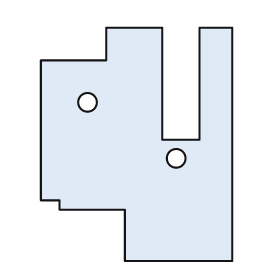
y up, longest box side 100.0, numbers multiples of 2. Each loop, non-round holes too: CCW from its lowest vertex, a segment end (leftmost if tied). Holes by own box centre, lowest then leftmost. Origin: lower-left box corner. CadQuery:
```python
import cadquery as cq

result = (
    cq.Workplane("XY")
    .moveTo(36.0, 0.0)
    .lineTo(82.0, 0.0)
    .lineTo(82.0, 100.0)
    .lineTo(68.0, 100.0)
    .lineTo(68.0, 52.0)
    .lineTo(52.0, 52.0)
    .lineTo(52.0, 100.0)
    .lineTo(28.0, 100.0)
    .lineTo(28.0, 86.0)
    .lineTo(0.0, 86.0)
    .lineTo(0.0, 26.0)
    .lineTo(8.0, 26.0)
    .lineTo(8.0, 22.0)
    .lineTo(36.0, 22.0)
    .close()
    .moveTo(58.0, 44.0)
    .circle(4.0)
    .moveTo(20.0, 68.0)
    .circle(4.0)
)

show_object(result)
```